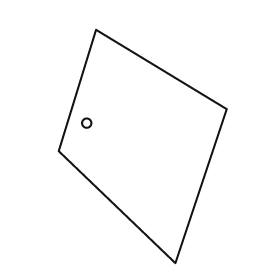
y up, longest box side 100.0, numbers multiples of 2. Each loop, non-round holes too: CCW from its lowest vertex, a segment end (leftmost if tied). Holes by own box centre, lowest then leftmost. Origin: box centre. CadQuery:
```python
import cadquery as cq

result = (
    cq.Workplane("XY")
    .moveTo(14.0, -50.0)
    .lineTo(36.0, 16.0)
    .lineTo(-20.0, 50.0)
    .lineTo(-36.0, -2.0)
    .close()
    .moveTo(-24.0, 10.0)
    .circle(2.0)
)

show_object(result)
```